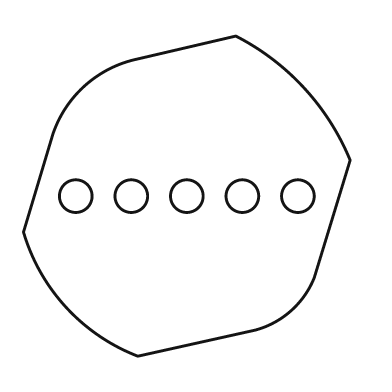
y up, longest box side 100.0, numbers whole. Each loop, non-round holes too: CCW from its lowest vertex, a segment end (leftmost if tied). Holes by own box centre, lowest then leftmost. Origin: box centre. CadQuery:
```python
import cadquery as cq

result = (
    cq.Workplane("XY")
    .moveTo(-15.0, -49.0)
    .lineTo(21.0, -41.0)
    .threePointArc((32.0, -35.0), (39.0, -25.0))
    .lineTo(50.0, 11.0)
    .threePointArc((36.0, 33.0), (15.0, 49.0))
    .lineTo(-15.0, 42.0)
    .threePointArc((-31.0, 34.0), (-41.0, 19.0))
    .lineTo(-50.0, -11.0)
    .threePointArc((-37.0, -34.0), (-15.0, -49.0))
    .close()
    .moveTo(-34.0, 0.0)
    .circle(5.0)
    .moveTo(-17.0, 0.0)
    .circle(5.0)
    .moveTo(0.0, 0.0)
    .circle(5.0)
    .moveTo(17.0, 0.0)
    .circle(5.0)
    .moveTo(34.0, 0.0)
    .circle(5.0)
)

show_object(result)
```